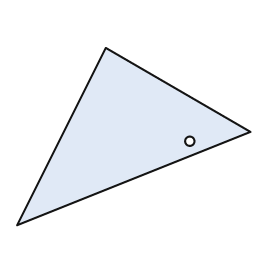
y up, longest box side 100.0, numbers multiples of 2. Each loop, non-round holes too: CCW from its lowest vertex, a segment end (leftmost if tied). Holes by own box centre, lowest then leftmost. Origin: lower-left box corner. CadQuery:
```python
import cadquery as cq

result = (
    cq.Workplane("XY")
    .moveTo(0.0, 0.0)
    .lineTo(100.0, 40.0)
    .lineTo(38.0, 76.0)
    .close()
    .moveTo(74.0, 36.0)
    .circle(2.0)
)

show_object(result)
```